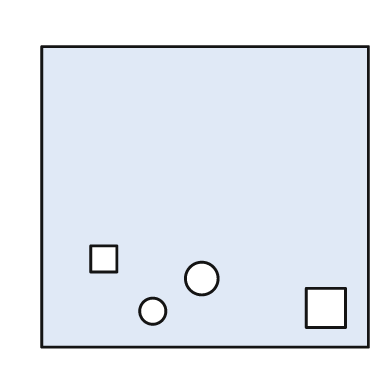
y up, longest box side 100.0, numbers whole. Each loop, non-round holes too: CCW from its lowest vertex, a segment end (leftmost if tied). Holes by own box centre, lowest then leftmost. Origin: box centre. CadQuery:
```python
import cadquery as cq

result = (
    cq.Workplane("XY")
    .moveTo(-50.0, -46.0)
    .lineTo(50.0, -46.0)
    .lineTo(50.0, 46.0)
    .lineTo(-50.0, 46.0)
    .close()
    .moveTo(-16.0, -35.0)
    .circle(4.0)
    .moveTo(31.0, -40.0)
    .lineTo(43.0, -40.0)
    .lineTo(43.0, -28.0)
    .lineTo(31.0, -28.0)
    .close()
    .moveTo(-1.0, -25.0)
    .circle(5.0)
    .moveTo(-35.0, -23.0)
    .lineTo(-27.0, -23.0)
    .lineTo(-27.0, -15.0)
    .lineTo(-35.0, -15.0)
    .close()
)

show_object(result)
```